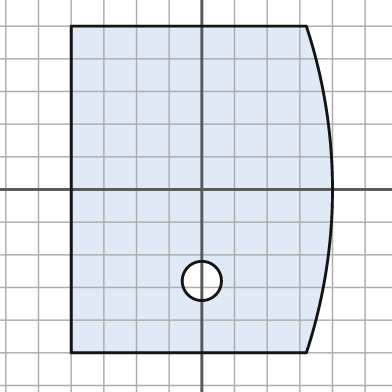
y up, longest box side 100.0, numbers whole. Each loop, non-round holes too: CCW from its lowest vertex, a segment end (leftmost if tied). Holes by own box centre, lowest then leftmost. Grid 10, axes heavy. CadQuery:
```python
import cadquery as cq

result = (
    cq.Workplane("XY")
    .moveTo(-40.0, -50.0)
    .lineTo(32.0, -50.0)
    .threePointArc((40.0, 0.0), (32.0, 50.0))
    .lineTo(-40.0, 50.0)
    .close()
    .moveTo(0.0, -28.0)
    .circle(6.0)
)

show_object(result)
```